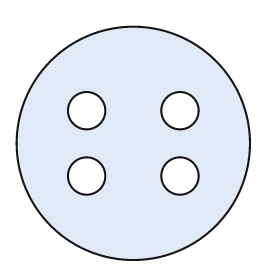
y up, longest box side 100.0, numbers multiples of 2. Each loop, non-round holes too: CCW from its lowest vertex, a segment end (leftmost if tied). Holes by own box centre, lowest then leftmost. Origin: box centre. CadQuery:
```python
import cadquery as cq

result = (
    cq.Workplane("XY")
    .moveTo(0.0, 0.0)
    .circle(50.0)
    .moveTo(-20.0, -14.0)
    .circle(8.0)
    .moveTo(20.0, -14.0)
    .circle(8.0)
    .moveTo(-20.0, 14.0)
    .circle(8.0)
    .moveTo(20.0, 14.0)
    .circle(8.0)
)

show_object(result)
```